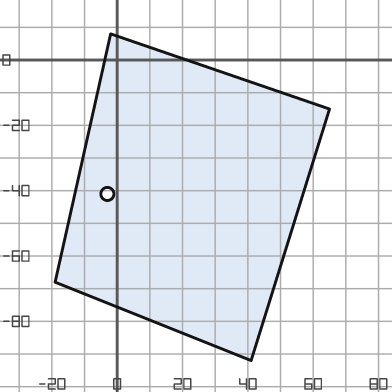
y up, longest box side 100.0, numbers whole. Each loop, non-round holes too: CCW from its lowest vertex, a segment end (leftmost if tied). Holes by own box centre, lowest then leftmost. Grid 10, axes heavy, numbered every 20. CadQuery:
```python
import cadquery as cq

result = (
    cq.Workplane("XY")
    .moveTo(41.0, -92.0)
    .lineTo(65.0, -15.0)
    .lineTo(-2.0, 8.0)
    .lineTo(-19.0, -68.0)
    .close()
    .moveTo(-3.0, -41.0)
    .circle(2.0)
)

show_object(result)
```